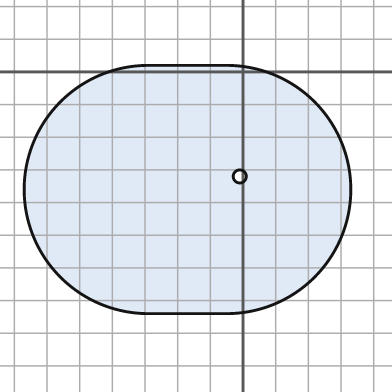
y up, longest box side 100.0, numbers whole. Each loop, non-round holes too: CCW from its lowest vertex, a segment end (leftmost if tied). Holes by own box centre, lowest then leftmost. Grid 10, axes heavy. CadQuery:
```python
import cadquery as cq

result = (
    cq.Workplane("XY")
    .moveTo(-29.0, -74.0)
    .lineTo(-5.0, -74.0)
    .threePointArc((33.0, -36.0), (-5.0, 2.0))
    .lineTo(-29.0, 2.0)
    .threePointArc((-67.0, -36.0), (-29.0, -74.0))
    .close()
    .moveTo(-1.0, -32.0)
    .circle(2.0)
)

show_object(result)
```